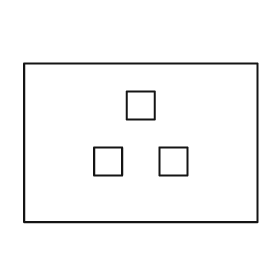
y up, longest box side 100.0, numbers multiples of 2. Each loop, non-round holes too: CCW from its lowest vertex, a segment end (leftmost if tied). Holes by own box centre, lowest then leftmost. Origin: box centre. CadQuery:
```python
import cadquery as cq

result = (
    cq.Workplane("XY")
    .moveTo(-50.0, -34.0)
    .lineTo(50.0, -34.0)
    .lineTo(50.0, 34.0)
    .lineTo(-50.0, 34.0)
    .close()
    .moveTo(-20.0, -14.0)
    .lineTo(-8.0, -14.0)
    .lineTo(-8.0, -2.0)
    .lineTo(-20.0, -2.0)
    .close()
    .moveTo(8.0, -14.0)
    .lineTo(20.0, -14.0)
    .lineTo(20.0, -2.0)
    .lineTo(8.0, -2.0)
    .close()
    .moveTo(-6.0, 10.0)
    .lineTo(6.0, 10.0)
    .lineTo(6.0, 22.0)
    .lineTo(-6.0, 22.0)
    .close()
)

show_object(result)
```